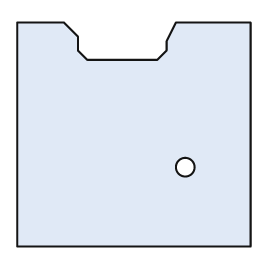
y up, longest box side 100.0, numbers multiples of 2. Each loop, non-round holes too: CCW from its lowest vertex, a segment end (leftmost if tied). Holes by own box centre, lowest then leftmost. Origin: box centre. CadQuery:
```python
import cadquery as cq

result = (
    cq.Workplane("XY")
    .moveTo(-50.0, -48.0)
    .lineTo(50.0, -48.0)
    .lineTo(50.0, 48.0)
    .lineTo(18.0, 48.0)
    .lineTo(14.0, 40.0)
    .lineTo(14.0, 36.0)
    .lineTo(10.0, 32.0)
    .lineTo(-20.0, 32.0)
    .lineTo(-24.0, 36.0)
    .lineTo(-24.0, 42.0)
    .lineTo(-30.0, 48.0)
    .lineTo(-50.0, 48.0)
    .close()
    .moveTo(22.0, -14.0)
    .circle(4.0)
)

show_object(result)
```